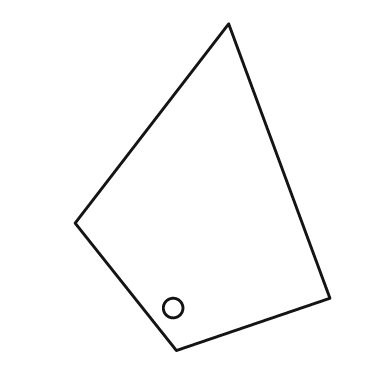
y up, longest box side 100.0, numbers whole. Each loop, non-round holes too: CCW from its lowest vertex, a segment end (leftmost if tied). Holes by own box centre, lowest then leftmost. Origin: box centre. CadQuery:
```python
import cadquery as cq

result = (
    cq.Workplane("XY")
    .moveTo(-8.0, -50.0)
    .lineTo(39.0, -34.0)
    .lineTo(8.0, 50.0)
    .lineTo(-39.0, -11.0)
    .close()
    .moveTo(-9.0, -37.0)
    .circle(3.0)
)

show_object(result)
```